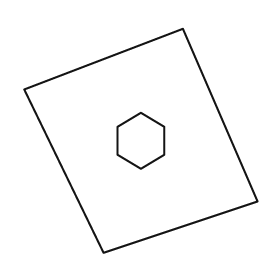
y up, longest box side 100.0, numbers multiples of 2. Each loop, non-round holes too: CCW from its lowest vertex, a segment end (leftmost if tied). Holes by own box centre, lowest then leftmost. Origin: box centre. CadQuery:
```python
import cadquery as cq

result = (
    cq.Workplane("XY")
    .moveTo(-16.0, -48.0)
    .lineTo(50.0, -26.0)
    .lineTo(18.0, 48.0)
    .lineTo(-50.0, 22.0)
    .close()
    .moveTo(0.0, -12.0)
    .lineTo(10.0, -6.0)
    .lineTo(10.0, 6.0)
    .lineTo(0.0, 12.0)
    .lineTo(-10.0, 6.0)
    .lineTo(-10.0, -6.0)
    .close()
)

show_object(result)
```